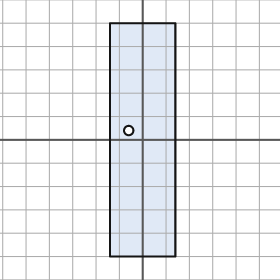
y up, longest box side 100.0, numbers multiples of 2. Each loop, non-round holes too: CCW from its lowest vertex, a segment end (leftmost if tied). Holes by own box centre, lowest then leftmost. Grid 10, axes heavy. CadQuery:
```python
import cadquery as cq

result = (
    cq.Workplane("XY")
    .moveTo(-14.0, -50.0)
    .lineTo(14.0, -50.0)
    .lineTo(14.0, 50.0)
    .lineTo(-14.0, 50.0)
    .close()
    .moveTo(-6.0, 4.0)
    .circle(2.0)
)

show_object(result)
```